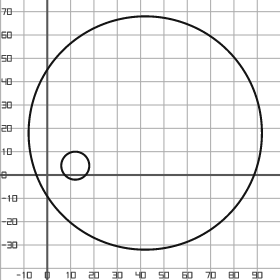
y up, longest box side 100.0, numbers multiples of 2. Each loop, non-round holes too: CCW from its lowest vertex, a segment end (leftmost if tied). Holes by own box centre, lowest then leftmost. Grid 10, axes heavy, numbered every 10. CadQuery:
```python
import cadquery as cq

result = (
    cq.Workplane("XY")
    .moveTo(42.0, 18.0)
    .circle(50.0)
    .moveTo(12.0, 4.0)
    .circle(6.0)
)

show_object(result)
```